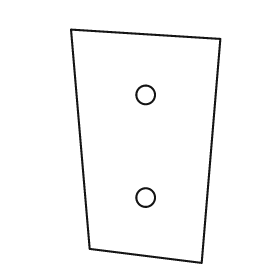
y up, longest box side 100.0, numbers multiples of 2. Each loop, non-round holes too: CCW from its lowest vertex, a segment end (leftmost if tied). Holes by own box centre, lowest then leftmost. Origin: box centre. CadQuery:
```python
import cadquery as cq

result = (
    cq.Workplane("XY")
    .moveTo(24.0, -50.0)
    .lineTo(32.0, 46.0)
    .lineTo(-32.0, 50.0)
    .lineTo(-24.0, -44.0)
    .close()
    .moveTo(0.0, -22.0)
    .circle(4.0)
    .moveTo(0.0, 22.0)
    .circle(4.0)
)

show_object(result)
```